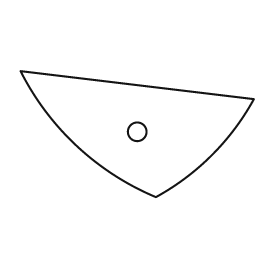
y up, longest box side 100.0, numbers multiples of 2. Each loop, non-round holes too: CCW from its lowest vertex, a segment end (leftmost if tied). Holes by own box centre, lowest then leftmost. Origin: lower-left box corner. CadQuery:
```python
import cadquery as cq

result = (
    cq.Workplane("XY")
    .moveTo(58.0, 0.0)
    .threePointArc((82.0, 18.0), (100.0, 42.0))
    .lineTo(0.0, 54.0)
    .threePointArc((24.0, 22.0), (58.0, 0.0))
    .close()
    .moveTo(50.0, 28.0)
    .circle(4.0)
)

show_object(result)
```